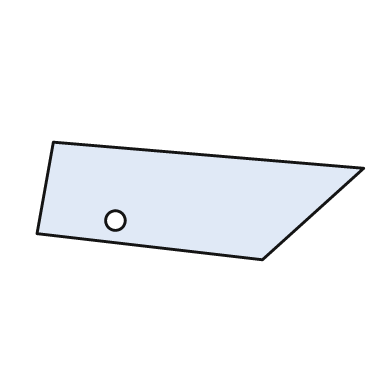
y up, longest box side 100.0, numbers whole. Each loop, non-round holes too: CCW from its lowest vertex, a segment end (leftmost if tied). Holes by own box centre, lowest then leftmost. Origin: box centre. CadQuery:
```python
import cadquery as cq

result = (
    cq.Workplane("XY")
    .moveTo(19.0, -18.0)
    .lineTo(50.0, 10.0)
    .lineTo(-45.0, 18.0)
    .lineTo(-50.0, -10.0)
    .close()
    .moveTo(-26.0, -6.0)
    .circle(3.0)
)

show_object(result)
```